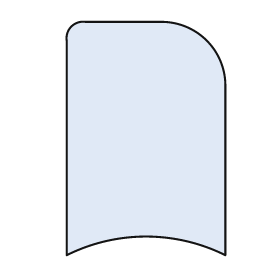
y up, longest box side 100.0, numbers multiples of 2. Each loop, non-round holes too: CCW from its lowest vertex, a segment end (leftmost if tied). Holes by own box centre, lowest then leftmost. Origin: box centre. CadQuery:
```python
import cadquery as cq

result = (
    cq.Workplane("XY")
    .moveTo(-34.0, -50.0)
    .threePointArc((0.0, -42.0), (34.0, -50.0))
    .lineTo(34.0, 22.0)
    .threePointArc((26.0, 42.0), (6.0, 50.0))
    .lineTo(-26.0, 50.0)
    .threePointArc((-32.0, 48.0), (-34.0, 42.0))
    .close()
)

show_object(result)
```